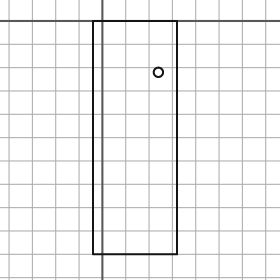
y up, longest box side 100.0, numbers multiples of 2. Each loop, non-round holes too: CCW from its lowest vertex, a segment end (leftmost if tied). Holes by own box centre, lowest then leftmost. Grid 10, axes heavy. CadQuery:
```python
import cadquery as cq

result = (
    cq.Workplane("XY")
    .moveTo(-4.0, -100.0)
    .lineTo(32.0, -100.0)
    .lineTo(32.0, 0.0)
    .lineTo(-4.0, 0.0)
    .close()
    .moveTo(24.0, -22.0)
    .circle(2.0)
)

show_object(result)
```